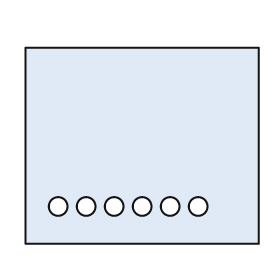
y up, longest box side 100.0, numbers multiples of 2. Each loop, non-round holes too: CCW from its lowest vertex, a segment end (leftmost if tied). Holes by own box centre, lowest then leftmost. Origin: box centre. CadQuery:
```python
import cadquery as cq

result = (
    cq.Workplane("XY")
    .moveTo(-50.0, -42.0)
    .lineTo(50.0, -42.0)
    .lineTo(50.0, 42.0)
    .lineTo(-50.0, 42.0)
    .close()
    .moveTo(-36.0, -26.0)
    .circle(4.0)
    .moveTo(-24.0, -26.0)
    .circle(4.0)
    .moveTo(-12.0, -26.0)
    .circle(4.0)
    .moveTo(0.0, -26.0)
    .circle(4.0)
    .moveTo(12.0, -26.0)
    .circle(4.0)
    .moveTo(24.0, -26.0)
    .circle(4.0)
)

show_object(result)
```